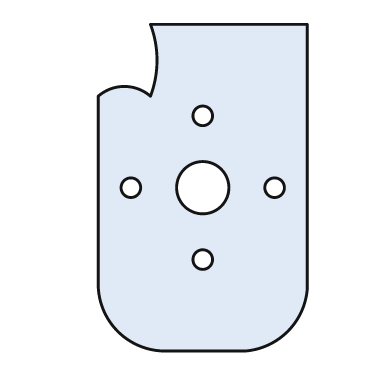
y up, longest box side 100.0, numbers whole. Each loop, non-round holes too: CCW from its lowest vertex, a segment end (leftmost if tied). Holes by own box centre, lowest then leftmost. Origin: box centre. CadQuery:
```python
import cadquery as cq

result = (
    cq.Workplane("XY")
    .moveTo(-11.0, -50.0)
    .lineTo(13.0, -50.0)
    .threePointArc((26.0, -44.0), (32.0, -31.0))
    .lineTo(32.0, 50.0)
    .lineTo(-16.0, 50.0)
    .threePointArc((-14.0, 39.0), (-16.0, 28.0))
    .threePointArc((-24.0, 31.0), (-32.0, 28.0))
    .lineTo(-32.0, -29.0)
    .threePointArc((-26.0, -44.0), (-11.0, -50.0))
    .close()
    .moveTo(0.0, -22.0)
    .circle(3.0)
    .moveTo(-22.0, 0.0)
    .circle(3.0)
    .moveTo(0.0, 0.0)
    .circle(8.0)
    .moveTo(22.0, 0.0)
    .circle(3.0)
    .moveTo(0.0, 22.0)
    .circle(3.0)
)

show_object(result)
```